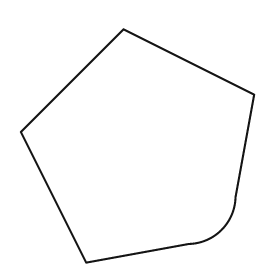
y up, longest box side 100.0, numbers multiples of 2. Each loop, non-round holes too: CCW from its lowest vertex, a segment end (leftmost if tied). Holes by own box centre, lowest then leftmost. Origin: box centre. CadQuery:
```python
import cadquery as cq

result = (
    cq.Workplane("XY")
    .moveTo(-22.0, -50.0)
    .lineTo(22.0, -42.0)
    .threePointArc((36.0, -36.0), (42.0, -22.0))
    .lineTo(50.0, 22.0)
    .lineTo(-6.0, 50.0)
    .lineTo(-50.0, 6.0)
    .close()
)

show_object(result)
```